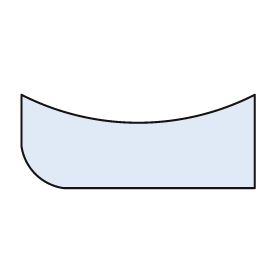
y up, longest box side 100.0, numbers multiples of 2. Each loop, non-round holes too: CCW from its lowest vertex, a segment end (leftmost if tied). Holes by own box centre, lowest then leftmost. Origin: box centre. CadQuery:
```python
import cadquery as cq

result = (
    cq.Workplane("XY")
    .moveTo(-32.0, -20.0)
    .lineTo(50.0, -20.0)
    .lineTo(50.0, 20.0)
    .threePointArc((0.0, 8.0), (-50.0, 20.0))
    .lineTo(-50.0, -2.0)
    .threePointArc((-44.0, -14.0), (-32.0, -20.0))
    .close()
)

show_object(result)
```